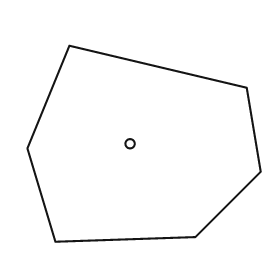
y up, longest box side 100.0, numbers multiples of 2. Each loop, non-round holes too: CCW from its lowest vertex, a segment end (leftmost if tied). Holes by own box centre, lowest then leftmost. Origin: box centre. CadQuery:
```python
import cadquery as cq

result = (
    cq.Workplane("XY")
    .moveTo(-38.0, -42.0)
    .lineTo(22.0, -40.0)
    .lineTo(50.0, -12.0)
    .lineTo(44.0, 24.0)
    .lineTo(-32.0, 42.0)
    .lineTo(-50.0, -2.0)
    .close()
    .moveTo(-6.0, 0.0)
    .circle(2.0)
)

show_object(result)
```